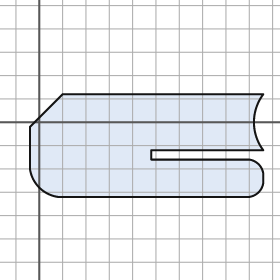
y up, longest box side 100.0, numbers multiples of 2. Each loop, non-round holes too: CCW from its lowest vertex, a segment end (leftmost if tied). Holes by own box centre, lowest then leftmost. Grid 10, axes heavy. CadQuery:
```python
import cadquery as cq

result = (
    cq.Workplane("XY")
    .moveTo(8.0, -32.0)
    .lineTo(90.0, -32.0)
    .threePointArc((94.0, -30.0), (96.0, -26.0))
    .lineTo(96.0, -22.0)
    .threePointArc((94.0, -18.0), (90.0, -16.0))
    .lineTo(48.0, -16.0)
    .lineTo(48.0, -12.0)
    .lineTo(96.0, -12.0)
    .threePointArc((92.0, 0.0), (96.0, 12.0))
    .lineTo(10.0, 12.0)
    .lineTo(-4.0, -2.0)
    .lineTo(-4.0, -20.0)
    .threePointArc((0.0, -28.0), (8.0, -32.0))
    .close()
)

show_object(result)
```